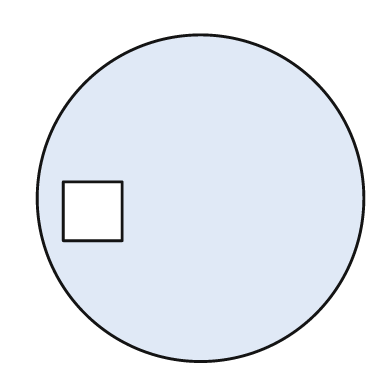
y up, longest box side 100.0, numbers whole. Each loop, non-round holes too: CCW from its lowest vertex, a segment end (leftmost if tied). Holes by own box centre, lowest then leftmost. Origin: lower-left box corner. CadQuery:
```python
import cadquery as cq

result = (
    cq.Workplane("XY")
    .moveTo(50.0, 50.0)
    .circle(50.0)
    .moveTo(8.0, 37.0)
    .lineTo(26.0, 37.0)
    .lineTo(26.0, 55.0)
    .lineTo(8.0, 55.0)
    .close()
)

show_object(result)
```